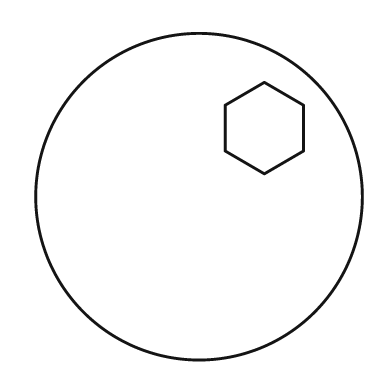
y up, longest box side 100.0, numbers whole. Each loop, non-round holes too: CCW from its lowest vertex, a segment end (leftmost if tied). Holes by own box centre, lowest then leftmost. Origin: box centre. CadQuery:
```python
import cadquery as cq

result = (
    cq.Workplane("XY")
    .moveTo(0.0, 0.0)
    .circle(50.0)
    .moveTo(20.0, 7.0)
    .lineTo(32.0, 14.0)
    .lineTo(32.0, 28.0)
    .lineTo(20.0, 35.0)
    .lineTo(8.0, 28.0)
    .lineTo(8.0, 14.0)
    .close()
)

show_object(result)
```